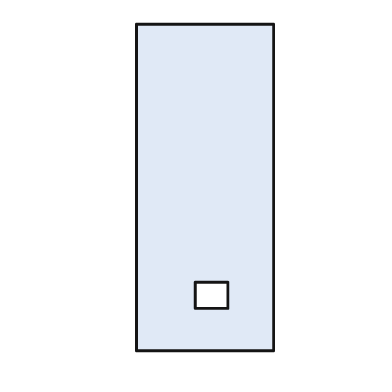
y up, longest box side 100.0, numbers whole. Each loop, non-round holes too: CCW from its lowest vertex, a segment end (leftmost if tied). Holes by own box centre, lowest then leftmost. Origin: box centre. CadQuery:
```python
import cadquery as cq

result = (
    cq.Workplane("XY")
    .moveTo(-21.0, -50.0)
    .lineTo(21.0, -50.0)
    .lineTo(21.0, 50.0)
    .lineTo(-21.0, 50.0)
    .close()
    .moveTo(-3.0, -37.0)
    .lineTo(7.0, -37.0)
    .lineTo(7.0, -29.0)
    .lineTo(-3.0, -29.0)
    .close()
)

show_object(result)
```